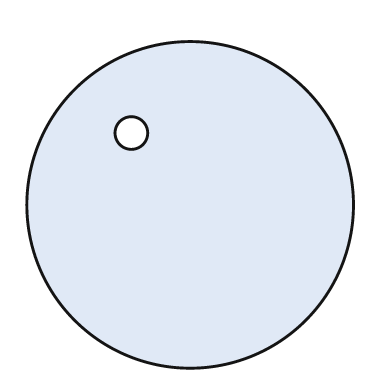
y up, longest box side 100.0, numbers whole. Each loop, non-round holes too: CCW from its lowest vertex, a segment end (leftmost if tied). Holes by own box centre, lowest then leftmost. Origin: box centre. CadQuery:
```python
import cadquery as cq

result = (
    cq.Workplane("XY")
    .moveTo(0.0, 0.0)
    .circle(50.0)
    .moveTo(-18.0, 22.0)
    .circle(5.0)
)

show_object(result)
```